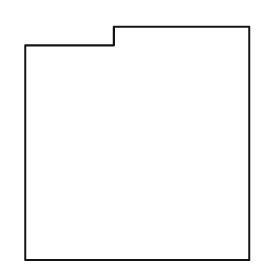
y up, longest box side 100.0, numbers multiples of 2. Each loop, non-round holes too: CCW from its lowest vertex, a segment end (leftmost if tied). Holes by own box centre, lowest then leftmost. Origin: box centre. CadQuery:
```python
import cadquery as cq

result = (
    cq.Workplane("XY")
    .moveTo(-48.0, -50.0)
    .lineTo(48.0, -50.0)
    .lineTo(48.0, 50.0)
    .lineTo(-10.0, 50.0)
    .lineTo(-10.0, 42.0)
    .lineTo(-48.0, 42.0)
    .close()
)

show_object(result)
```